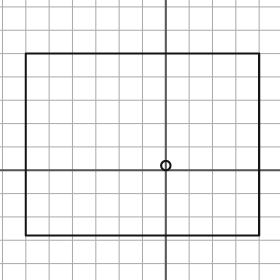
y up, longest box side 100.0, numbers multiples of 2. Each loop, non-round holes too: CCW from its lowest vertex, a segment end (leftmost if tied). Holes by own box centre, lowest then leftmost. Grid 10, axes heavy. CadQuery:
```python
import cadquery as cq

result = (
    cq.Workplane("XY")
    .moveTo(-60.0, -28.0)
    .lineTo(40.0, -28.0)
    .lineTo(40.0, 50.0)
    .lineTo(-60.0, 50.0)
    .close()
    .moveTo(0.0, 2.0)
    .circle(2.0)
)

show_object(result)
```